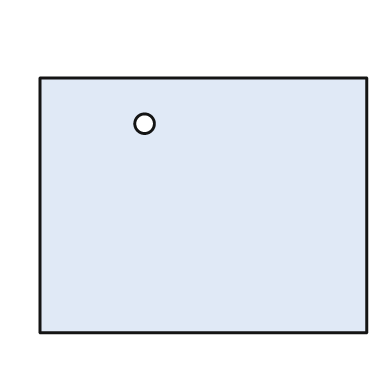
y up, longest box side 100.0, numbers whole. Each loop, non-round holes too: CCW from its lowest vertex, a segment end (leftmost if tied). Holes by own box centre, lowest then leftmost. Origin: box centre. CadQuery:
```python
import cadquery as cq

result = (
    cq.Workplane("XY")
    .moveTo(-50.0, -39.0)
    .lineTo(50.0, -39.0)
    .lineTo(50.0, 39.0)
    .lineTo(-50.0, 39.0)
    .close()
    .moveTo(-18.0, 25.0)
    .circle(3.0)
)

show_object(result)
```